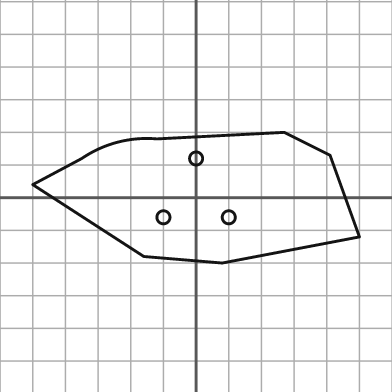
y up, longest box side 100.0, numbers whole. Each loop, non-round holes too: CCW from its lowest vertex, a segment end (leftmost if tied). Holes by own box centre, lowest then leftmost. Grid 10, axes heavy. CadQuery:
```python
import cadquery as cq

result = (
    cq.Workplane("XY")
    .moveTo(8.0, -20.0)
    .lineTo(50.0, -12.0)
    .lineTo(41.0, 13.0)
    .lineTo(27.0, 20.0)
    .lineTo(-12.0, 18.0)
    .threePointArc((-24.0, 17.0), (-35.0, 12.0))
    .lineTo(-50.0, 4.0)
    .lineTo(-16.0, -18.0)
    .close()
    .moveTo(-10.0, -6.0)
    .circle(2.0)
    .moveTo(10.0, -6.0)
    .circle(2.0)
    .moveTo(0.0, 12.0)
    .circle(2.0)
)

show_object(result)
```